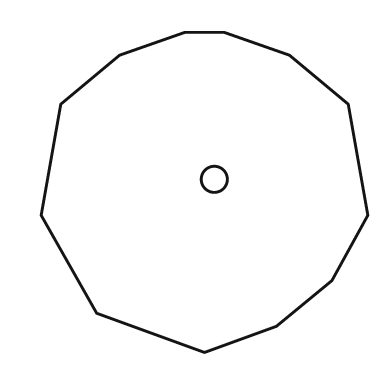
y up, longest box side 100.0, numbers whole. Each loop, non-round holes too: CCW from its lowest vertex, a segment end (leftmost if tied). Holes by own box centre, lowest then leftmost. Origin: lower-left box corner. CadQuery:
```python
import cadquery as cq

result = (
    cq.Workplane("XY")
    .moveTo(50.0, 0.0)
    .lineTo(72.0, 8.0)
    .lineTo(89.0, 22.0)
    .lineTo(100.0, 42.0)
    .lineTo(94.0, 76.0)
    .lineTo(76.0, 91.0)
    .lineTo(56.0, 98.0)
    .lineTo(44.0, 98.0)
    .lineTo(24.0, 91.0)
    .lineTo(6.0, 76.0)
    .lineTo(0.0, 42.0)
    .lineTo(17.0, 12.0)
    .close()
    .moveTo(53.0, 53.0)
    .circle(4.0)
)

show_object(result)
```